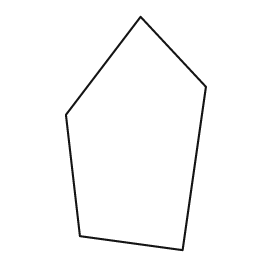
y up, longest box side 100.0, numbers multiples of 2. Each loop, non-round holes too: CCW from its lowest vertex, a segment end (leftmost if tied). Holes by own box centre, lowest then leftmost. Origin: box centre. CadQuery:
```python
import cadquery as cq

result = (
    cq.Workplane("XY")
    .moveTo(20.0, -50.0)
    .lineTo(30.0, 20.0)
    .lineTo(2.0, 50.0)
    .lineTo(-30.0, 8.0)
    .lineTo(-24.0, -44.0)
    .close()
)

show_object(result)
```